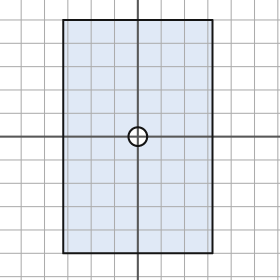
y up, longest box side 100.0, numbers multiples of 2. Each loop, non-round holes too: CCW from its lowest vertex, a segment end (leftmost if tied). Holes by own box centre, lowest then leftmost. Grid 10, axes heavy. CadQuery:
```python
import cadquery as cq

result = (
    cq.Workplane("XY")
    .moveTo(-32.0, -50.0)
    .lineTo(32.0, -50.0)
    .lineTo(32.0, 50.0)
    .lineTo(-32.0, 50.0)
    .close()
    .moveTo(0.0, 0.0)
    .circle(4.0)
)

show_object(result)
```